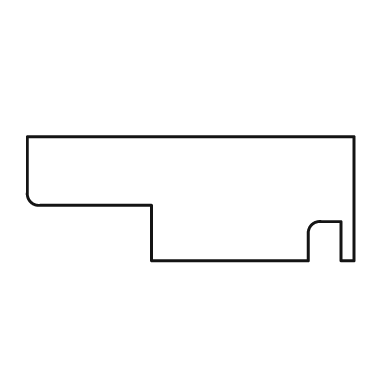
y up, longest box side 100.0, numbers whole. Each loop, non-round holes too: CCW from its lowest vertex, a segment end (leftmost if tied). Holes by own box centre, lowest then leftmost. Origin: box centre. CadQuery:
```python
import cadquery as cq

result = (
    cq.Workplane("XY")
    .moveTo(-12.0, -19.0)
    .lineTo(36.0, -19.0)
    .lineTo(36.0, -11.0)
    .threePointArc((37.0, -8.0), (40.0, -7.0))
    .lineTo(46.0, -7.0)
    .lineTo(46.0, -19.0)
    .lineTo(50.0, -19.0)
    .lineTo(50.0, 19.0)
    .lineTo(-50.0, 19.0)
    .lineTo(-50.0, 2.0)
    .threePointArc((-49.0, -1.0), (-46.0, -2.0))
    .lineTo(-12.0, -2.0)
    .close()
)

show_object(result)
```